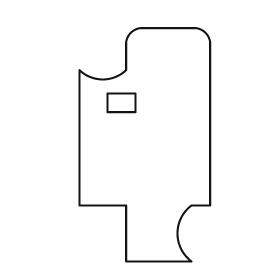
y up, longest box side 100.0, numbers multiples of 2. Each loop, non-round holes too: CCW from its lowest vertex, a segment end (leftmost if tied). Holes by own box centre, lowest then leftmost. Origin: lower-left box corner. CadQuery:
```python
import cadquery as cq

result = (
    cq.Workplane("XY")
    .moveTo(20.0, 0.0)
    .lineTo(48.0, 0.0)
    .threePointArc((42.0, 12.0), (48.0, 24.0))
    .lineTo(56.0, 24.0)
    .lineTo(56.0, 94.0)
    .threePointArc((54.0, 98.0), (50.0, 100.0))
    .lineTo(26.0, 100.0)
    .threePointArc((22.0, 98.0), (20.0, 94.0))
    .lineTo(20.0, 82.0)
    .threePointArc((10.0, 78.0), (0.0, 82.0))
    .lineTo(0.0, 24.0)
    .lineTo(20.0, 24.0)
    .close()
    .moveTo(12.0, 64.0)
    .lineTo(24.0, 64.0)
    .lineTo(24.0, 72.0)
    .lineTo(12.0, 72.0)
    .close()
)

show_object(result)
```